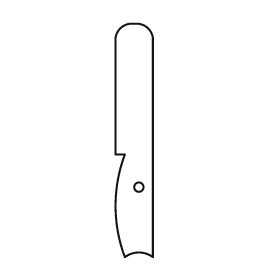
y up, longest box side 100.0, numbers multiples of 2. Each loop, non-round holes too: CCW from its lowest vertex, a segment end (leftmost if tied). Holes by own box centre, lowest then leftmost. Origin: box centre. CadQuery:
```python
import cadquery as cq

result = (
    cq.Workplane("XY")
    .moveTo(-4.0, -50.0)
    .threePointArc((2.0, -48.0), (8.0, -50.0))
    .lineTo(8.0, 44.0)
    .threePointArc((6.0, 48.0), (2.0, 50.0))
    .lineTo(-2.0, 50.0)
    .threePointArc((-6.0, 48.0), (-8.0, 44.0))
    .lineTo(-8.0, -6.0)
    .lineTo(-4.0, -6.0)
    .threePointArc((-8.0, -28.0), (-4.0, -50.0))
    .close()
    .moveTo(2.0, -20.0)
    .circle(2.0)
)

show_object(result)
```